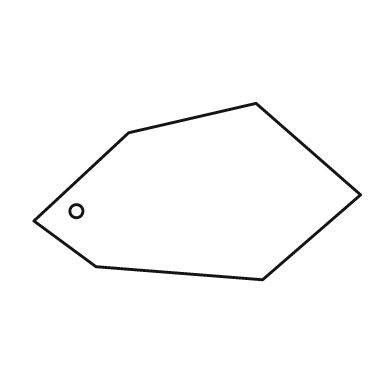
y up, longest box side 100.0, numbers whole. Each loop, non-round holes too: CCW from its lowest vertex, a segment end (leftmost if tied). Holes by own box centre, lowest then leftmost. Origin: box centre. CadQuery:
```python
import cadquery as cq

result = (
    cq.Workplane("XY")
    .moveTo(20.0, -27.0)
    .lineTo(50.0, -1.0)
    .lineTo(18.0, 27.0)
    .lineTo(-21.0, 18.0)
    .lineTo(-50.0, -9.0)
    .lineTo(-31.0, -23.0)
    .close()
    .moveTo(-37.0, -6.0)
    .circle(2.0)
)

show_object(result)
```